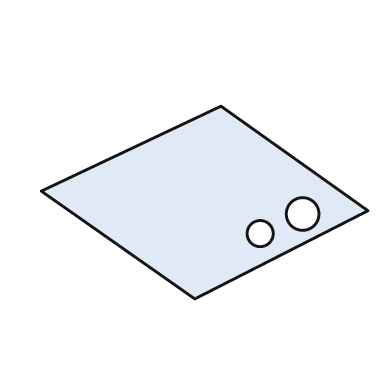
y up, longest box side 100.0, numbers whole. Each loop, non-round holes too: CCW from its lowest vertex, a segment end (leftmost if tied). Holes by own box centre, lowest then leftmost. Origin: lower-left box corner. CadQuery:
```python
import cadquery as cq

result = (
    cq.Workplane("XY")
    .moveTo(47.0, 0.0)
    .lineTo(100.0, 27.0)
    .lineTo(55.0, 59.0)
    .lineTo(0.0, 33.0)
    .close()
    .moveTo(67.0, 20.0)
    .circle(4.0)
    .moveTo(80.0, 26.0)
    .circle(5.0)
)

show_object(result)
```